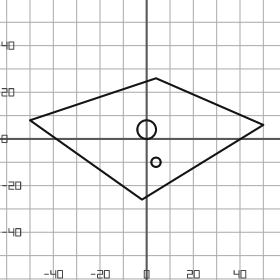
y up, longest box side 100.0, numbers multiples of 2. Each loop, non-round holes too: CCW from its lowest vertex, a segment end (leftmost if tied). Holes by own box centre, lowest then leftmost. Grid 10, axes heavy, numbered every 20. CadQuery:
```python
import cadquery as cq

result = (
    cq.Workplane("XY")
    .moveTo(-2.0, -26.0)
    .lineTo(50.0, 6.0)
    .lineTo(4.0, 26.0)
    .lineTo(-50.0, 8.0)
    .close()
    .moveTo(4.0, -10.0)
    .circle(2.0)
    .moveTo(0.0, 4.0)
    .circle(4.0)
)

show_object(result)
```